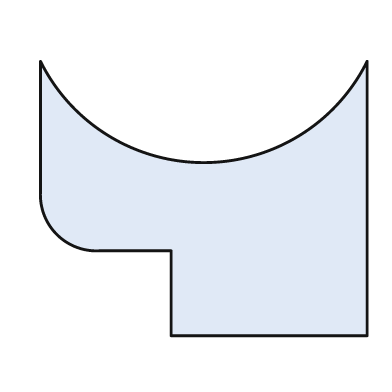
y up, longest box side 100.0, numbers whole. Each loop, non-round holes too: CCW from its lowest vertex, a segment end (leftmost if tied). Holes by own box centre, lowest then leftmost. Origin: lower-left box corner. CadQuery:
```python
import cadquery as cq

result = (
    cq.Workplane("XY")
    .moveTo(40.0, 0.0)
    .lineTo(100.0, 0.0)
    .lineTo(100.0, 84.0)
    .threePointArc((50.0, 53.0), (0.0, 84.0))
    .lineTo(0.0, 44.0)
    .threePointArc((5.0, 31.0), (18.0, 26.0))
    .lineTo(40.0, 26.0)
    .close()
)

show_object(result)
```